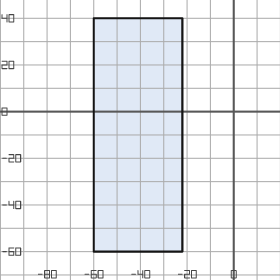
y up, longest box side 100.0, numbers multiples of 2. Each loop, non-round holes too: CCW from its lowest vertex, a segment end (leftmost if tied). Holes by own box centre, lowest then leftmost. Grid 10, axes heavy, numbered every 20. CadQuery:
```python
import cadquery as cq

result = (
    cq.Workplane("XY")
    .moveTo(-60.0, -60.0)
    .lineTo(-22.0, -60.0)
    .lineTo(-22.0, 40.0)
    .lineTo(-60.0, 40.0)
    .close()
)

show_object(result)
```